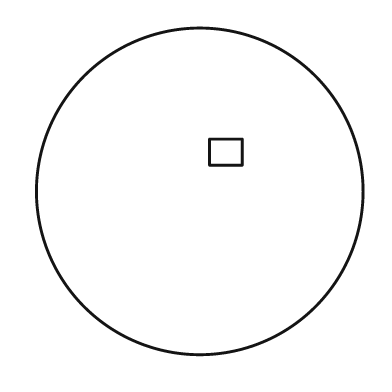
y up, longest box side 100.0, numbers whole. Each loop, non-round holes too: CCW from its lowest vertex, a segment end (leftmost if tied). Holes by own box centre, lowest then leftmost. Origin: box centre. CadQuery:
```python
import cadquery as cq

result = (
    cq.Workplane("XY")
    .moveTo(0.0, 0.0)
    .circle(50.0)
    .moveTo(3.0, 8.0)
    .lineTo(13.0, 8.0)
    .lineTo(13.0, 16.0)
    .lineTo(3.0, 16.0)
    .close()
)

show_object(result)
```